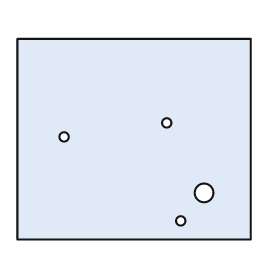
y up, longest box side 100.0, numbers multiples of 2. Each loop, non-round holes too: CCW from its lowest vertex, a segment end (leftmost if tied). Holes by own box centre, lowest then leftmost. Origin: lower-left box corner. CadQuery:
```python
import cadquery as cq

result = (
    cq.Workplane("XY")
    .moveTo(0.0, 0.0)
    .lineTo(100.0, 0.0)
    .lineTo(100.0, 86.0)
    .lineTo(0.0, 86.0)
    .close()
    .moveTo(70.0, 8.0)
    .circle(2.0)
    .moveTo(80.0, 20.0)
    .circle(4.0)
    .moveTo(20.0, 44.0)
    .circle(2.0)
    .moveTo(64.0, 50.0)
    .circle(2.0)
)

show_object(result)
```